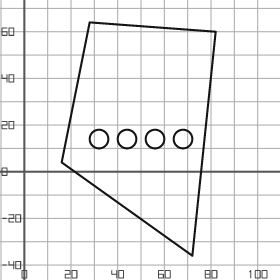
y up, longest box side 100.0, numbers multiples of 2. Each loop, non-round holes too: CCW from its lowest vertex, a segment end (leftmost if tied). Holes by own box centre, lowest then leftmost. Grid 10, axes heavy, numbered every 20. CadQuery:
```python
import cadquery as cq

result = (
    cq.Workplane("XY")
    .moveTo(72.0, -36.0)
    .lineTo(82.0, 60.0)
    .lineTo(28.0, 64.0)
    .lineTo(16.0, 4.0)
    .close()
    .moveTo(32.0, 14.0)
    .circle(4.0)
    .moveTo(44.0, 14.0)
    .circle(4.0)
    .moveTo(56.0, 14.0)
    .circle(4.0)
    .moveTo(68.0, 14.0)
    .circle(4.0)
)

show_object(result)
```